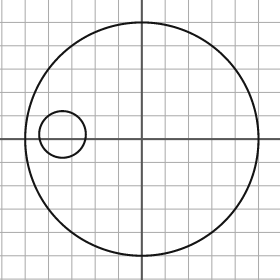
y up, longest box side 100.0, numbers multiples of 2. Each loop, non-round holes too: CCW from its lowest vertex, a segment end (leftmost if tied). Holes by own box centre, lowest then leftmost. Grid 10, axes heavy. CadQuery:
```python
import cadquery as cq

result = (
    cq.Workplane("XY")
    .moveTo(0.0, 0.0)
    .circle(50.0)
    .moveTo(-34.0, 2.0)
    .circle(10.0)
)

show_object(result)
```